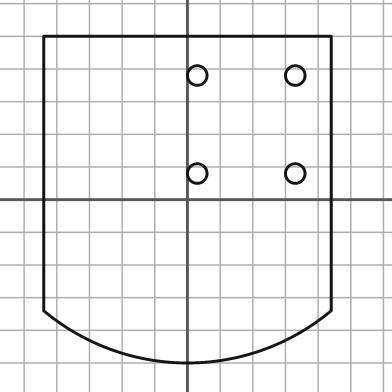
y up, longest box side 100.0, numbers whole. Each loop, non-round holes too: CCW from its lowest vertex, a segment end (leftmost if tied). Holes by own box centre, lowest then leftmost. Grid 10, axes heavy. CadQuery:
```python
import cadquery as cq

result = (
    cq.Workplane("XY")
    .moveTo(-44.0, -34.0)
    .threePointArc((0.0, -50.0), (44.0, -34.0))
    .lineTo(44.0, 50.0)
    .lineTo(-44.0, 50.0)
    .close()
    .moveTo(3.0, 8.0)
    .circle(3.0)
    .moveTo(33.0, 8.0)
    .circle(3.0)
    .moveTo(3.0, 38.0)
    .circle(3.0)
    .moveTo(33.0, 38.0)
    .circle(3.0)
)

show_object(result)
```